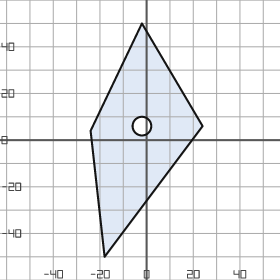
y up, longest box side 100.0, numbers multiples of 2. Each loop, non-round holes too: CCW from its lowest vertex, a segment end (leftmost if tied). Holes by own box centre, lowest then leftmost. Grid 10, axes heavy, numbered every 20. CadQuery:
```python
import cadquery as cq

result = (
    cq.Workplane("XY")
    .moveTo(-18.0, -50.0)
    .lineTo(24.0, 6.0)
    .lineTo(-2.0, 50.0)
    .lineTo(-24.0, 4.0)
    .close()
    .moveTo(-2.0, 6.0)
    .circle(4.0)
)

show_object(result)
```